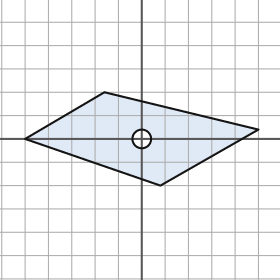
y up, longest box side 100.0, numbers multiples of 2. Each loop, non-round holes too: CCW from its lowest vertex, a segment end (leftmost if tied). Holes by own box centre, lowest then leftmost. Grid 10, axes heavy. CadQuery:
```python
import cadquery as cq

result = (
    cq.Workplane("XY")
    .moveTo(8.0, -20.0)
    .lineTo(50.0, 4.0)
    .lineTo(-16.0, 20.0)
    .lineTo(-50.0, 0.0)
    .close()
    .moveTo(0.0, 0.0)
    .circle(4.0)
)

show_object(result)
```